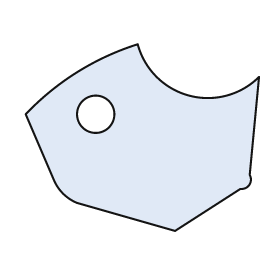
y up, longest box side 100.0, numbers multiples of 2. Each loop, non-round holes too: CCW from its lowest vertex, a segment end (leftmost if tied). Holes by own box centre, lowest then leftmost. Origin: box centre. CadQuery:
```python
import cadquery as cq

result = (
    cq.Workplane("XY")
    .moveTo(14.0, -40.0)
    .lineTo(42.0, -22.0)
    .threePointArc((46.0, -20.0), (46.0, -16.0))
    .lineTo(50.0, 26.0)
    .threePointArc((20.0, 18.0), (-2.0, 40.0))
    .threePointArc((-28.0, 28.0), (-50.0, 10.0))
    .lineTo(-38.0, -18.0)
    .threePointArc((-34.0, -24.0), (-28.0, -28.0))
    .close()
    .moveTo(-20.0, 10.0)
    .circle(8.0)
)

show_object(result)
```